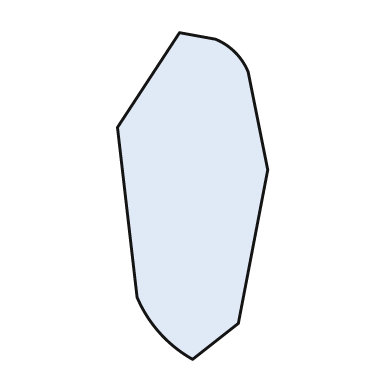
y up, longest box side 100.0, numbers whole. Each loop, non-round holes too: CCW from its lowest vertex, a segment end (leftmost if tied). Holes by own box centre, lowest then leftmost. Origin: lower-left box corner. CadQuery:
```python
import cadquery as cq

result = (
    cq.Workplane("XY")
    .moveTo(23.0, 0.0)
    .lineTo(37.0, 11.0)
    .lineTo(46.0, 58.0)
    .lineTo(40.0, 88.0)
    .threePointArc((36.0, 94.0), (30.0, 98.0))
    .lineTo(19.0, 100.0)
    .lineTo(0.0, 71.0)
    .lineTo(6.0, 19.0)
    .threePointArc((13.0, 8.0), (23.0, 0.0))
    .close()
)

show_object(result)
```